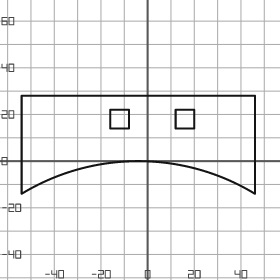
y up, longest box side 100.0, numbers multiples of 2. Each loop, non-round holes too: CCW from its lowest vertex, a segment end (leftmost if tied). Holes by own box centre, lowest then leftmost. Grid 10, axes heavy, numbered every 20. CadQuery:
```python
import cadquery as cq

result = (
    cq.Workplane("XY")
    .moveTo(-54.0, -14.0)
    .threePointArc((-4.0, 0.0), (46.0, -14.0))
    .lineTo(46.0, 28.0)
    .lineTo(-54.0, 28.0)
    .close()
    .moveTo(-16.0, 14.0)
    .lineTo(-8.0, 14.0)
    .lineTo(-8.0, 22.0)
    .lineTo(-16.0, 22.0)
    .close()
    .moveTo(12.0, 14.0)
    .lineTo(20.0, 14.0)
    .lineTo(20.0, 22.0)
    .lineTo(12.0, 22.0)
    .close()
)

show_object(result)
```